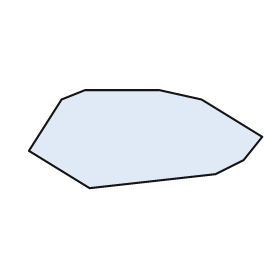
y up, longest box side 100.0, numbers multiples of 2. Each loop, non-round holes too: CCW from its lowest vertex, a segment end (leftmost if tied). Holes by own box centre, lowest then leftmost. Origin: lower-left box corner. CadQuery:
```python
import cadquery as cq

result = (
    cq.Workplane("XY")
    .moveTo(26.0, 0.0)
    .lineTo(80.0, 6.0)
    .lineTo(92.0, 12.0)
    .lineTo(100.0, 22.0)
    .lineTo(74.0, 38.0)
    .lineTo(56.0, 42.0)
    .lineTo(24.0, 42.0)
    .lineTo(14.0, 38.0)
    .lineTo(0.0, 16.0)
    .close()
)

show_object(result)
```